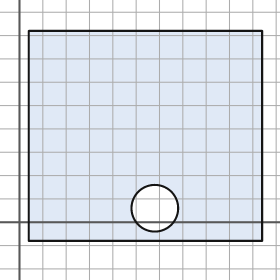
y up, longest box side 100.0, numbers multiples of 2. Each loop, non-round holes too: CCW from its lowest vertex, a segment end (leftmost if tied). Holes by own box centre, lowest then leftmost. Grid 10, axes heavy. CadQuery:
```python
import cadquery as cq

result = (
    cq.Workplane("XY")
    .moveTo(4.0, -8.0)
    .lineTo(104.0, -8.0)
    .lineTo(104.0, 82.0)
    .lineTo(4.0, 82.0)
    .close()
    .moveTo(58.0, 6.0)
    .circle(10.0)
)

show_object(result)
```